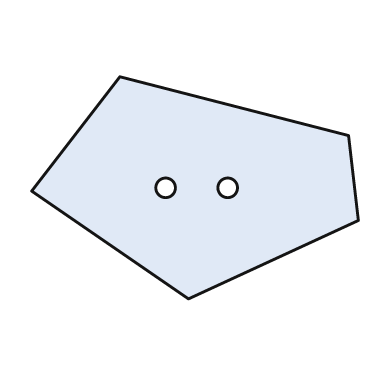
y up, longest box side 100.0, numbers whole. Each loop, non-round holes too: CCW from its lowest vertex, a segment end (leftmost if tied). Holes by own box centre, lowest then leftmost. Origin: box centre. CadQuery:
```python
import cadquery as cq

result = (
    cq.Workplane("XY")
    .moveTo(-2.0, -34.0)
    .lineTo(50.0, -10.0)
    .lineTo(47.0, 16.0)
    .lineTo(-23.0, 34.0)
    .lineTo(-50.0, -1.0)
    .close()
    .moveTo(-9.0, 0.0)
    .circle(3.0)
    .moveTo(10.0, 0.0)
    .circle(3.0)
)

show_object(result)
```